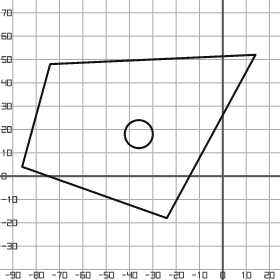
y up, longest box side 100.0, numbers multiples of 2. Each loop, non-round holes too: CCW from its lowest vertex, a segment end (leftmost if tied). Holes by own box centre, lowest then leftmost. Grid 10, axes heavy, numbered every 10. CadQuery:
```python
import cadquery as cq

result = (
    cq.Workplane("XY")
    .moveTo(-24.0, -18.0)
    .lineTo(14.0, 52.0)
    .lineTo(-74.0, 48.0)
    .lineTo(-86.0, 4.0)
    .close()
    .moveTo(-36.0, 18.0)
    .circle(6.0)
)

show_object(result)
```